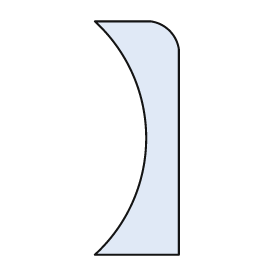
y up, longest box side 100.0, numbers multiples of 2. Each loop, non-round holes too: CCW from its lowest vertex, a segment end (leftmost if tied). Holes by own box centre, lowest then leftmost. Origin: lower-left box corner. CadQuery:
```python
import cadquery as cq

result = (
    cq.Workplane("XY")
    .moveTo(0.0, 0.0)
    .lineTo(36.0, 0.0)
    .lineTo(36.0, 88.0)
    .threePointArc((32.0, 96.0), (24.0, 100.0))
    .lineTo(0.0, 100.0)
    .threePointArc((22.0, 50.0), (0.0, 0.0))
    .close()
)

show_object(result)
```